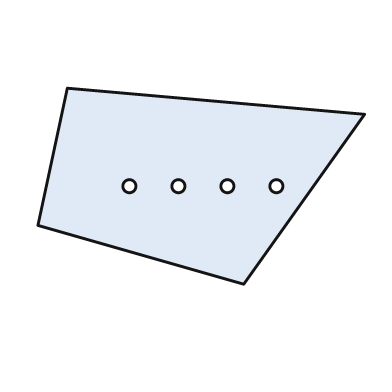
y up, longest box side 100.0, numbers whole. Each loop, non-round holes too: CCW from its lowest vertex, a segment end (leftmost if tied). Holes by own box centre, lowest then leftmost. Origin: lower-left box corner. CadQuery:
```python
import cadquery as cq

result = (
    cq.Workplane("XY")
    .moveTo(63.0, 0.0)
    .lineTo(100.0, 52.0)
    .lineTo(9.0, 60.0)
    .lineTo(0.0, 18.0)
    .close()
    .moveTo(28.0, 30.0)
    .circle(2.0)
    .moveTo(43.0, 30.0)
    .circle(2.0)
    .moveTo(58.0, 30.0)
    .circle(2.0)
    .moveTo(73.0, 30.0)
    .circle(2.0)
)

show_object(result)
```